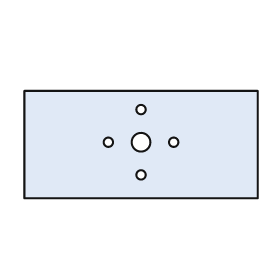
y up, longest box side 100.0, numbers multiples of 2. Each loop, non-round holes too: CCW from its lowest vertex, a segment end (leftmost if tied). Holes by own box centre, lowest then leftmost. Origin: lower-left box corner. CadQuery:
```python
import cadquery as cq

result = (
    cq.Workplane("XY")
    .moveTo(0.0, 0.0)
    .lineTo(100.0, 0.0)
    .lineTo(100.0, 46.0)
    .lineTo(0.0, 46.0)
    .close()
    .moveTo(50.0, 10.0)
    .circle(2.0)
    .moveTo(36.0, 24.0)
    .circle(2.0)
    .moveTo(50.0, 24.0)
    .circle(4.0)
    .moveTo(64.0, 24.0)
    .circle(2.0)
    .moveTo(50.0, 38.0)
    .circle(2.0)
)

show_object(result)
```